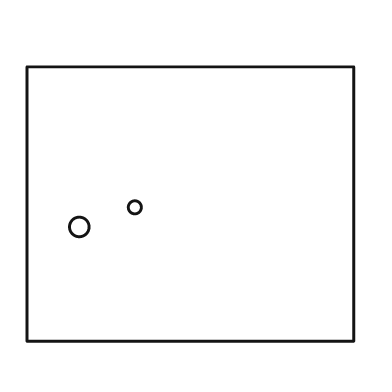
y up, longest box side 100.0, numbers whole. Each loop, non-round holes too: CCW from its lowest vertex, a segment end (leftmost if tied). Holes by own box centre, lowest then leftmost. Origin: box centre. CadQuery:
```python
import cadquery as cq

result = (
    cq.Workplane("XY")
    .moveTo(-50.0, -42.0)
    .lineTo(50.0, -42.0)
    .lineTo(50.0, 42.0)
    .lineTo(-50.0, 42.0)
    .close()
    .moveTo(-34.0, -7.0)
    .circle(3.0)
    .moveTo(-17.0, -1.0)
    .circle(2.0)
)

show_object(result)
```